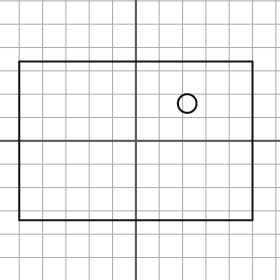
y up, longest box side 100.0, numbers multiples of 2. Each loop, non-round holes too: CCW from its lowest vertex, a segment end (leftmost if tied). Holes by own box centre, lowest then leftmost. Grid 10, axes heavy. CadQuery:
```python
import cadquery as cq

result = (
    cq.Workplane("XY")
    .moveTo(-50.0, -34.0)
    .lineTo(50.0, -34.0)
    .lineTo(50.0, 34.0)
    .lineTo(-50.0, 34.0)
    .close()
    .moveTo(22.0, 16.0)
    .circle(4.0)
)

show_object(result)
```